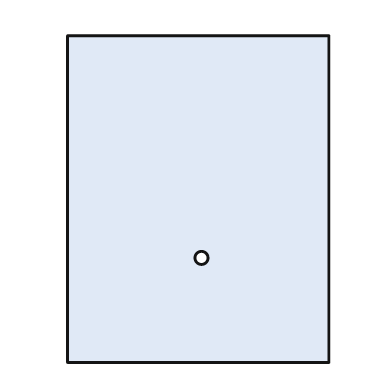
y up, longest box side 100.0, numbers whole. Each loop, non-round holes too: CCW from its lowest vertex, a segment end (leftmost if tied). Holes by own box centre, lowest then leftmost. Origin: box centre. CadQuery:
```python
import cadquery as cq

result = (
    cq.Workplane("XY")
    .moveTo(-40.0, -50.0)
    .lineTo(40.0, -50.0)
    .lineTo(40.0, 50.0)
    .lineTo(-40.0, 50.0)
    .close()
    .moveTo(1.0, -18.0)
    .circle(2.0)
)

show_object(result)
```